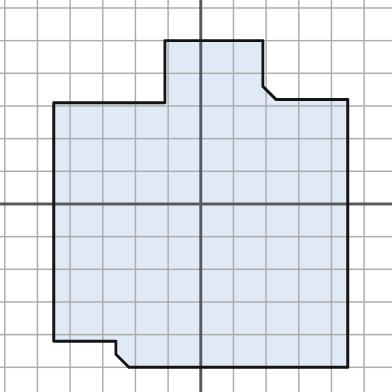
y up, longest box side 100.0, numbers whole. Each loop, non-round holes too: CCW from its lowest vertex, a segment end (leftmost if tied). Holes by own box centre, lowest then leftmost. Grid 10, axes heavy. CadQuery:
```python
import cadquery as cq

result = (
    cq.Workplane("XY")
    .moveTo(-22.0, -50.0)
    .lineTo(45.0, -50.0)
    .lineTo(45.0, 32.0)
    .lineTo(23.0, 32.0)
    .lineTo(19.0, 36.0)
    .lineTo(19.0, 50.0)
    .lineTo(-11.0, 50.0)
    .lineTo(-11.0, 31.0)
    .lineTo(-45.0, 31.0)
    .lineTo(-45.0, -42.0)
    .lineTo(-26.0, -42.0)
    .lineTo(-26.0, -46.0)
    .close()
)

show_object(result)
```